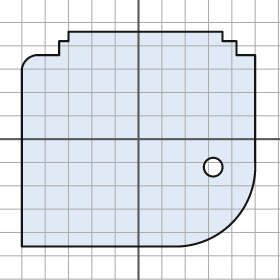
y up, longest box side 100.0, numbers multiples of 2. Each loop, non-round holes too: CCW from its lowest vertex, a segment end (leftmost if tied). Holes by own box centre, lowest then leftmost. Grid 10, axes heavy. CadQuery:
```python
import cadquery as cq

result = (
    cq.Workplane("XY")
    .moveTo(-50.0, -46.0)
    .lineTo(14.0, -46.0)
    .threePointArc((40.0, -36.0), (50.0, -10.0))
    .lineTo(50.0, 36.0)
    .lineTo(42.0, 36.0)
    .lineTo(42.0, 42.0)
    .lineTo(36.0, 42.0)
    .lineTo(36.0, 46.0)
    .lineTo(-30.0, 46.0)
    .lineTo(-30.0, 42.0)
    .lineTo(-34.0, 42.0)
    .lineTo(-34.0, 36.0)
    .lineTo(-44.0, 36.0)
    .threePointArc((-48.0, 34.0), (-50.0, 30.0))
    .close()
    .moveTo(32.0, -12.0)
    .circle(4.0)
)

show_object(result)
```